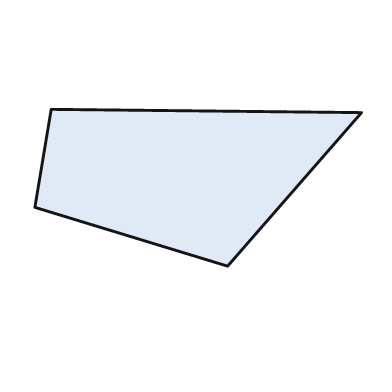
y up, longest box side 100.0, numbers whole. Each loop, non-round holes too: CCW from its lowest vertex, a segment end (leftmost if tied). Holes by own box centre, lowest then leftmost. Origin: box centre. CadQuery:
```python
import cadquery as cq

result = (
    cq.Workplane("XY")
    .moveTo(9.0, -24.0)
    .lineTo(50.0, 23.0)
    .lineTo(-45.0, 24.0)
    .lineTo(-50.0, -6.0)
    .close()
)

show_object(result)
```